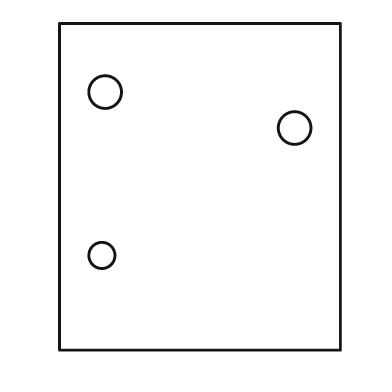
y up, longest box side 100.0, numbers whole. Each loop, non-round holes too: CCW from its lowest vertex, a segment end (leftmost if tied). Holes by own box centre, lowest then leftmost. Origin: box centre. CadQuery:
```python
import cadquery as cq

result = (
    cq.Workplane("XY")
    .moveTo(-43.0, -50.0)
    .lineTo(43.0, -50.0)
    .lineTo(43.0, 50.0)
    .lineTo(-43.0, 50.0)
    .close()
    .moveTo(-30.0, -21.0)
    .circle(4.0)
    .moveTo(29.0, 18.0)
    .circle(5.0)
    .moveTo(-29.0, 29.0)
    .circle(5.0)
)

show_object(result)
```